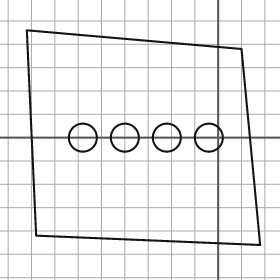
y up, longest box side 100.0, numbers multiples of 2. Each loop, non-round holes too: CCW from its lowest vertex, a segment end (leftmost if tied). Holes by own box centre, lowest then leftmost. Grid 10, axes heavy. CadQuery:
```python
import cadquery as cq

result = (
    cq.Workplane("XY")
    .moveTo(18.0, -46.0)
    .lineTo(10.0, 38.0)
    .lineTo(-82.0, 46.0)
    .lineTo(-78.0, -42.0)
    .close()
    .moveTo(-58.0, 0.0)
    .circle(6.0)
    .moveTo(-40.0, 0.0)
    .circle(6.0)
    .moveTo(-22.0, 0.0)
    .circle(6.0)
    .moveTo(-4.0, 0.0)
    .circle(6.0)
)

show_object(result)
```